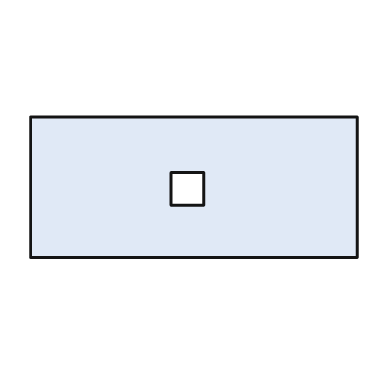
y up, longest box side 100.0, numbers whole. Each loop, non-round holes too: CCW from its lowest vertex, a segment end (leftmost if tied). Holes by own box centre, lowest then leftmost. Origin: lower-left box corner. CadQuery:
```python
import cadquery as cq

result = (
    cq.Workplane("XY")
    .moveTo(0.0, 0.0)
    .lineTo(100.0, 0.0)
    .lineTo(100.0, 43.0)
    .lineTo(0.0, 43.0)
    .close()
    .moveTo(43.0, 16.0)
    .lineTo(53.0, 16.0)
    .lineTo(53.0, 26.0)
    .lineTo(43.0, 26.0)
    .close()
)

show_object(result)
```